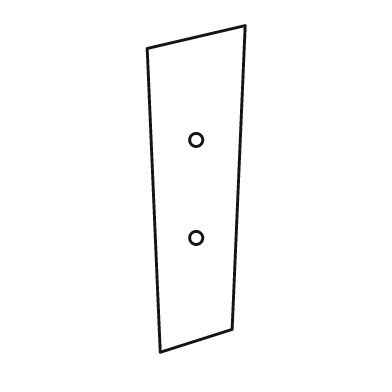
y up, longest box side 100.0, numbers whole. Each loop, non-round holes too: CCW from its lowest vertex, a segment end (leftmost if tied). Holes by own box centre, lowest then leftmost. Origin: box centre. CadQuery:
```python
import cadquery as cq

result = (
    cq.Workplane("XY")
    .moveTo(-11.0, -50.0)
    .lineTo(11.0, -43.0)
    .lineTo(15.0, 50.0)
    .lineTo(-15.0, 43.0)
    .close()
    .moveTo(0.0, -15.0)
    .circle(2.0)
    .moveTo(0.0, 15.0)
    .circle(2.0)
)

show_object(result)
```